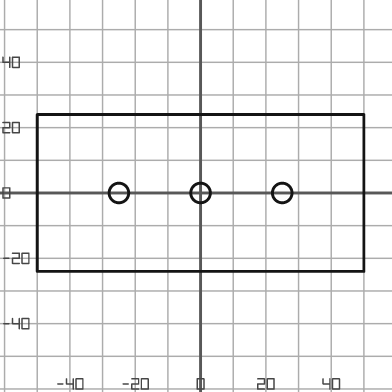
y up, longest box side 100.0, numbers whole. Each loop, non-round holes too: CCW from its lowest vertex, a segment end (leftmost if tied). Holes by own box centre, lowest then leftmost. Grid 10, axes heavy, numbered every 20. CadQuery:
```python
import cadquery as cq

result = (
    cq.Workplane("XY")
    .moveTo(-50.0, -24.0)
    .lineTo(50.0, -24.0)
    .lineTo(50.0, 24.0)
    .lineTo(-50.0, 24.0)
    .close()
    .moveTo(-25.0, 0.0)
    .circle(3.0)
    .moveTo(0.0, 0.0)
    .circle(3.0)
    .moveTo(25.0, 0.0)
    .circle(3.0)
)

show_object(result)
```